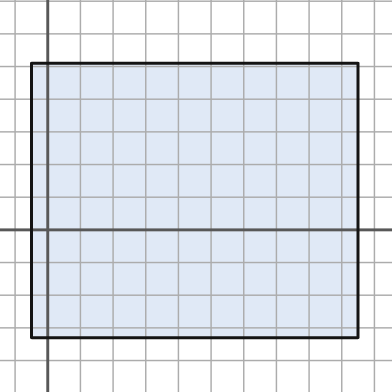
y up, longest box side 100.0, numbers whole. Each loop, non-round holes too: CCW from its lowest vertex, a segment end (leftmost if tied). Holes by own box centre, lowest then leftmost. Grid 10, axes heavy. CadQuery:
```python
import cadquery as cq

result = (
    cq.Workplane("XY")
    .moveTo(-5.0, -33.0)
    .lineTo(95.0, -33.0)
    .lineTo(95.0, 51.0)
    .lineTo(-5.0, 51.0)
    .close()
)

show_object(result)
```